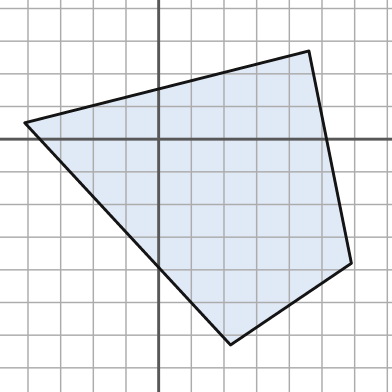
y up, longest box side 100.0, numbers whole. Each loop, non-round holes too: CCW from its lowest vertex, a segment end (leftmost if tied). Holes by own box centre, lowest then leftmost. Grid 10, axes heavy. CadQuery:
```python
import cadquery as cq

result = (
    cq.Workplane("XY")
    .moveTo(22.0, -63.0)
    .lineTo(59.0, -38.0)
    .lineTo(46.0, 27.0)
    .lineTo(-41.0, 5.0)
    .close()
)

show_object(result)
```